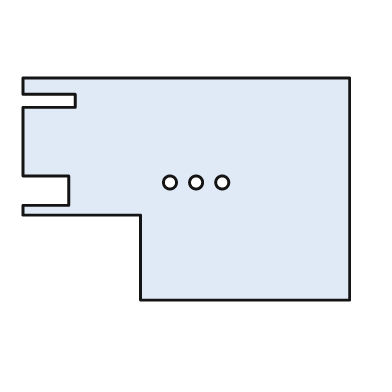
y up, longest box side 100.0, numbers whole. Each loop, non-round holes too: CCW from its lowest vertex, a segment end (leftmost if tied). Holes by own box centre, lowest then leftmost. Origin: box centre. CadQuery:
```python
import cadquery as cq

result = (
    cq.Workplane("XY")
    .moveTo(-14.0, -34.0)
    .lineTo(50.0, -34.0)
    .lineTo(50.0, 34.0)
    .lineTo(-50.0, 34.0)
    .lineTo(-50.0, 29.0)
    .lineTo(-34.0, 29.0)
    .lineTo(-34.0, 25.0)
    .lineTo(-50.0, 25.0)
    .lineTo(-50.0, 4.0)
    .lineTo(-36.0, 4.0)
    .lineTo(-36.0, -5.0)
    .lineTo(-50.0, -5.0)
    .lineTo(-50.0, -8.0)
    .lineTo(-14.0, -8.0)
    .close()
    .moveTo(-5.0, 2.0)
    .circle(2.0)
    .moveTo(3.0, 2.0)
    .circle(2.0)
    .moveTo(11.0, 2.0)
    .circle(2.0)
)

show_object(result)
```